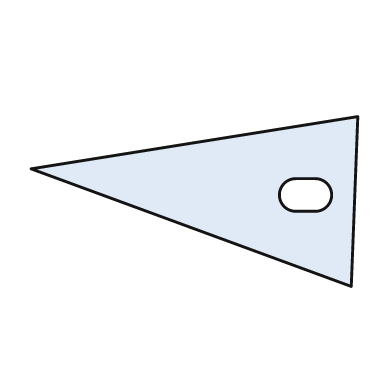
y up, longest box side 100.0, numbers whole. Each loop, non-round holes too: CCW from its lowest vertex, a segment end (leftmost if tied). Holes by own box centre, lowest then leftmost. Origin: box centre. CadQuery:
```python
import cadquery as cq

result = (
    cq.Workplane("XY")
    .moveTo(48.0, -26.0)
    .lineTo(50.0, 26.0)
    .lineTo(-50.0, 10.0)
    .close()
    .moveTo(31.0, -3.0)
    .lineTo(37.0, -3.0)
    .threePointArc((42.0, 2.0), (37.0, 7.0))
    .lineTo(31.0, 7.0)
    .threePointArc((26.0, 2.0), (31.0, -3.0))
    .close()
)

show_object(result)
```